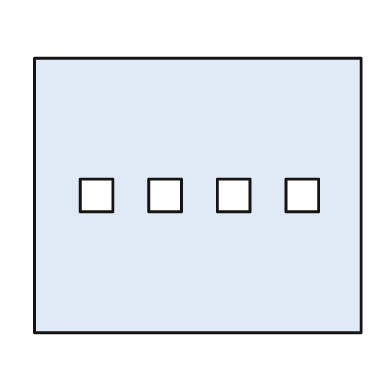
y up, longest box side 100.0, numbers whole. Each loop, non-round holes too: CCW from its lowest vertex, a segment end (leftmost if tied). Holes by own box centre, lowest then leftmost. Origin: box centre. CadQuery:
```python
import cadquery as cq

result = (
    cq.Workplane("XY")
    .moveTo(-50.0, -42.0)
    .lineTo(50.0, -42.0)
    .lineTo(50.0, 42.0)
    .lineTo(-50.0, 42.0)
    .close()
    .moveTo(-36.0, -5.0)
    .lineTo(-26.0, -5.0)
    .lineTo(-26.0, 5.0)
    .lineTo(-36.0, 5.0)
    .close()
    .moveTo(-15.0, -5.0)
    .lineTo(-5.0, -5.0)
    .lineTo(-5.0, 5.0)
    .lineTo(-15.0, 5.0)
    .close()
    .moveTo(6.0, -5.0)
    .lineTo(16.0, -5.0)
    .lineTo(16.0, 5.0)
    .lineTo(6.0, 5.0)
    .close()
    .moveTo(27.0, -5.0)
    .lineTo(37.0, -5.0)
    .lineTo(37.0, 5.0)
    .lineTo(27.0, 5.0)
    .close()
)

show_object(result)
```